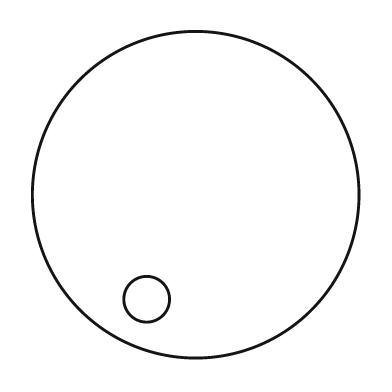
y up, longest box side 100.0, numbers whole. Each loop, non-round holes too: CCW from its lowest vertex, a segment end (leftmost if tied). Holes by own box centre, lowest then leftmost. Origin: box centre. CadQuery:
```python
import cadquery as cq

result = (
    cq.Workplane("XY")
    .moveTo(0.0, 0.0)
    .circle(50.0)
    .moveTo(-15.0, -32.0)
    .circle(7.0)
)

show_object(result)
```